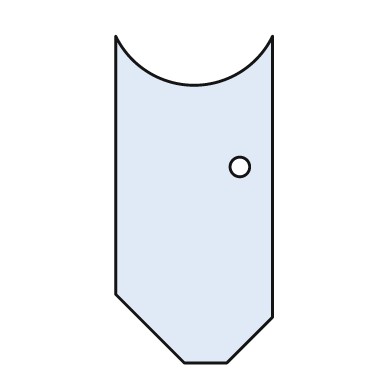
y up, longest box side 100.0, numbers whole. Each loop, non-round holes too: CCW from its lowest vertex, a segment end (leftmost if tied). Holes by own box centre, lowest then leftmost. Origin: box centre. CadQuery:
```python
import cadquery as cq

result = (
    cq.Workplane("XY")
    .moveTo(-3.0, -50.0)
    .lineTo(10.0, -50.0)
    .lineTo(24.0, -36.0)
    .lineTo(24.0, 50.0)
    .threePointArc((0.0, 35.0), (-24.0, 50.0))
    .lineTo(-24.0, -29.0)
    .close()
    .moveTo(14.0, 10.0)
    .circle(3.0)
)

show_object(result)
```